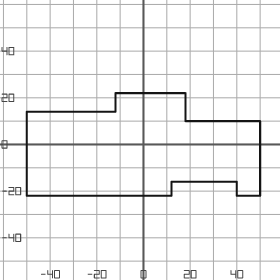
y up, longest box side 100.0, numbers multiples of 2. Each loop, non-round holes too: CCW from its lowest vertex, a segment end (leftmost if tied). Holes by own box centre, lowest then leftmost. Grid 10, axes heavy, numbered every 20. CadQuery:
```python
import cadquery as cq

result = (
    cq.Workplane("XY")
    .moveTo(-50.0, -22.0)
    .lineTo(12.0, -22.0)
    .lineTo(12.0, -16.0)
    .lineTo(40.0, -16.0)
    .lineTo(40.0, -22.0)
    .lineTo(50.0, -22.0)
    .lineTo(50.0, 10.0)
    .lineTo(18.0, 10.0)
    .lineTo(18.0, 22.0)
    .lineTo(-12.0, 22.0)
    .lineTo(-12.0, 14.0)
    .lineTo(-50.0, 14.0)
    .close()
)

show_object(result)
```